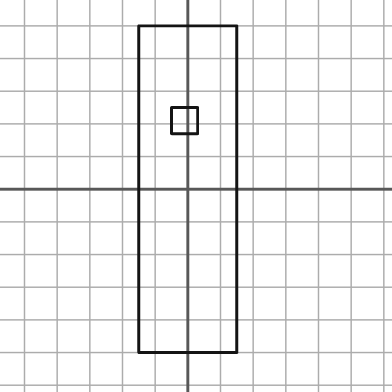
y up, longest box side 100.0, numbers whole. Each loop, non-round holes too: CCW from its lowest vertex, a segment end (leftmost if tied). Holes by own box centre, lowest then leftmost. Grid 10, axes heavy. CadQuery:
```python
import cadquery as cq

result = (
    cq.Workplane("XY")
    .moveTo(-15.0, -50.0)
    .lineTo(15.0, -50.0)
    .lineTo(15.0, 50.0)
    .lineTo(-15.0, 50.0)
    .close()
    .moveTo(-5.0, 17.0)
    .lineTo(3.0, 17.0)
    .lineTo(3.0, 25.0)
    .lineTo(-5.0, 25.0)
    .close()
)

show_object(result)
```